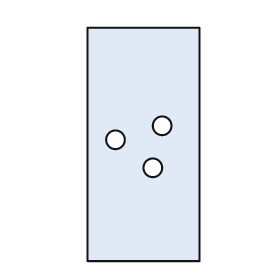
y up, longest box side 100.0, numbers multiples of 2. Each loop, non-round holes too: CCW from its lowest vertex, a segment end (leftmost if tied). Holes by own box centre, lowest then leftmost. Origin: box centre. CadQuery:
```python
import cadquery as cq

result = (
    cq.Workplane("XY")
    .moveTo(-24.0, -50.0)
    .lineTo(24.0, -50.0)
    .lineTo(24.0, 50.0)
    .lineTo(-24.0, 50.0)
    .close()
    .moveTo(4.0, -10.0)
    .circle(4.0)
    .moveTo(-12.0, 2.0)
    .circle(4.0)
    .moveTo(8.0, 8.0)
    .circle(4.0)
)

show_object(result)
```